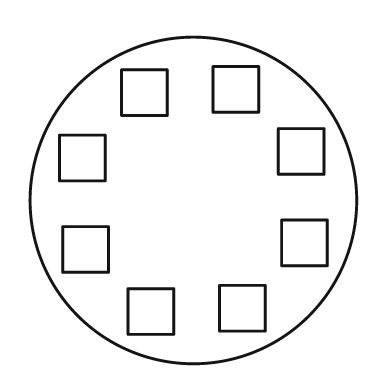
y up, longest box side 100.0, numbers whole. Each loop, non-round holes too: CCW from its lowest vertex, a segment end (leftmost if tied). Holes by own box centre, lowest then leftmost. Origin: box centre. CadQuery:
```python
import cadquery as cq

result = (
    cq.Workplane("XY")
    .moveTo(0.0, 0.0)
    .circle(50.0)
    .moveTo(-20.0, -41.0)
    .lineTo(-6.0, -41.0)
    .lineTo(-6.0, -27.0)
    .lineTo(-20.0, -27.0)
    .close()
    .moveTo(8.0, -40.0)
    .lineTo(22.0, -40.0)
    .lineTo(22.0, -26.0)
    .lineTo(8.0, -26.0)
    .close()
    .moveTo(-40.0, -22.0)
    .lineTo(-26.0, -22.0)
    .lineTo(-26.0, -8.0)
    .lineTo(-40.0, -8.0)
    .close()
    .moveTo(27.0, -20.0)
    .lineTo(41.0, -20.0)
    .lineTo(41.0, -6.0)
    .lineTo(27.0, -6.0)
    .close()
    .moveTo(-41.0, 6.0)
    .lineTo(-27.0, 6.0)
    .lineTo(-27.0, 20.0)
    .lineTo(-41.0, 20.0)
    .close()
    .moveTo(26.0, 8.0)
    .lineTo(40.0, 8.0)
    .lineTo(40.0, 22.0)
    .lineTo(26.0, 22.0)
    .close()
    .moveTo(-22.0, 26.0)
    .lineTo(-8.0, 26.0)
    .lineTo(-8.0, 40.0)
    .lineTo(-22.0, 40.0)
    .close()
    .moveTo(6.0, 27.0)
    .lineTo(20.0, 27.0)
    .lineTo(20.0, 41.0)
    .lineTo(6.0, 41.0)
    .close()
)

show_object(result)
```